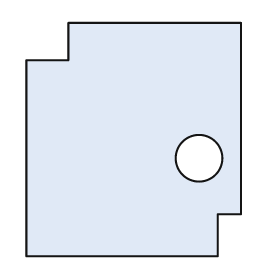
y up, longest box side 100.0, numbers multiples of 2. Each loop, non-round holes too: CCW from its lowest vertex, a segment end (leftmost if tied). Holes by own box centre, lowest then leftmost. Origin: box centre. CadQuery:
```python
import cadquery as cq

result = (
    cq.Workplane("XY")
    .moveTo(-46.0, -50.0)
    .lineTo(36.0, -50.0)
    .lineTo(36.0, -32.0)
    .lineTo(46.0, -32.0)
    .lineTo(46.0, 50.0)
    .lineTo(-28.0, 50.0)
    .lineTo(-28.0, 34.0)
    .lineTo(-46.0, 34.0)
    .close()
    .moveTo(28.0, -8.0)
    .circle(10.0)
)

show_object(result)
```